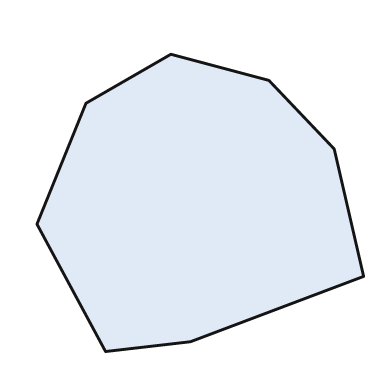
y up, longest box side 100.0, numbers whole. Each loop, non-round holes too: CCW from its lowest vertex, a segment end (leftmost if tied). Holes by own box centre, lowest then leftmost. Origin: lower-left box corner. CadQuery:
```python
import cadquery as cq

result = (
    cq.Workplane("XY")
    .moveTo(21.0, 0.0)
    .lineTo(47.0, 3.0)
    .lineTo(100.0, 23.0)
    .lineTo(91.0, 62.0)
    .lineTo(71.0, 83.0)
    .lineTo(41.0, 91.0)
    .lineTo(15.0, 76.0)
    .lineTo(0.0, 39.0)
    .close()
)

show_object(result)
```